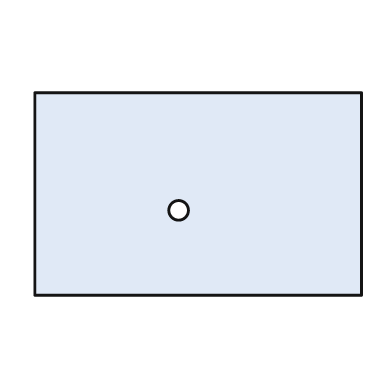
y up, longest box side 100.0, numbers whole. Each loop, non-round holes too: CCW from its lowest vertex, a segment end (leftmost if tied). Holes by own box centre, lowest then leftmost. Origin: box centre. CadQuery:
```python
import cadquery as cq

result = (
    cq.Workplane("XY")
    .moveTo(-50.0, -31.0)
    .lineTo(50.0, -31.0)
    .lineTo(50.0, 31.0)
    .lineTo(-50.0, 31.0)
    .close()
    .moveTo(-6.0, -5.0)
    .circle(3.0)
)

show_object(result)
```